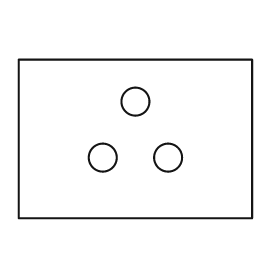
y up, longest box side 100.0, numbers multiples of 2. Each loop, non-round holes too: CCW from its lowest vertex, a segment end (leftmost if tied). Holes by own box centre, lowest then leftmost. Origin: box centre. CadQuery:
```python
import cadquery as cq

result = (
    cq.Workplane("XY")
    .moveTo(-50.0, -34.0)
    .lineTo(50.0, -34.0)
    .lineTo(50.0, 34.0)
    .lineTo(-50.0, 34.0)
    .close()
    .moveTo(-14.0, -8.0)
    .circle(6.0)
    .moveTo(14.0, -8.0)
    .circle(6.0)
    .moveTo(0.0, 16.0)
    .circle(6.0)
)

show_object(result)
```